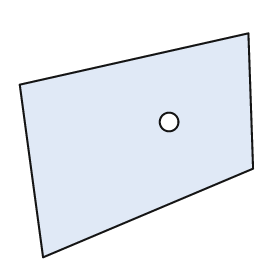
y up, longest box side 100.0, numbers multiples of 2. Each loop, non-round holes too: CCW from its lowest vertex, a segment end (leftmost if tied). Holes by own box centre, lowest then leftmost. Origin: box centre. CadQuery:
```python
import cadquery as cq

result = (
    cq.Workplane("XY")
    .moveTo(-40.0, -48.0)
    .lineTo(50.0, -10.0)
    .lineTo(48.0, 48.0)
    .lineTo(-50.0, 26.0)
    .close()
    .moveTo(14.0, 10.0)
    .circle(4.0)
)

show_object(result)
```